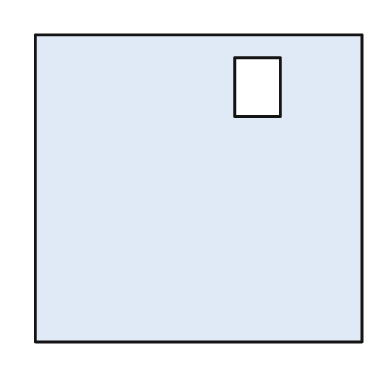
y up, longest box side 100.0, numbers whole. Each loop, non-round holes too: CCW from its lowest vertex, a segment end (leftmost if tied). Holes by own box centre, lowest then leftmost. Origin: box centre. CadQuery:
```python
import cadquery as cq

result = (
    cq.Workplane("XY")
    .moveTo(-50.0, -47.0)
    .lineTo(50.0, -47.0)
    .lineTo(50.0, 47.0)
    .lineTo(-50.0, 47.0)
    .close()
    .moveTo(11.0, 22.0)
    .lineTo(25.0, 22.0)
    .lineTo(25.0, 40.0)
    .lineTo(11.0, 40.0)
    .close()
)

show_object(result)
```